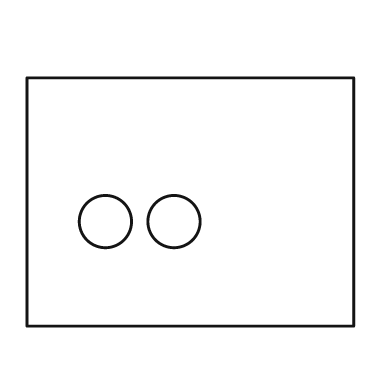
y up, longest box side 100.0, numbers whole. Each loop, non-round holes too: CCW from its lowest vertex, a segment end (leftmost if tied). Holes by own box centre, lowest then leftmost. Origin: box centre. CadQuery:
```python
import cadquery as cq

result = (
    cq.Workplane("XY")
    .moveTo(-50.0, -38.0)
    .lineTo(50.0, -38.0)
    .lineTo(50.0, 38.0)
    .lineTo(-50.0, 38.0)
    .close()
    .moveTo(-26.0, -6.0)
    .circle(8.0)
    .moveTo(-5.0, -6.0)
    .circle(8.0)
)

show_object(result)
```